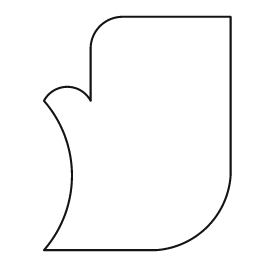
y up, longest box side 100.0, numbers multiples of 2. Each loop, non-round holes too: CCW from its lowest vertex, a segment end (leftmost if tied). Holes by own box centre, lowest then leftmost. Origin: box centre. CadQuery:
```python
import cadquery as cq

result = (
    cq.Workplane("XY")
    .moveTo(-40.0, -50.0)
    .lineTo(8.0, -50.0)
    .threePointArc((30.0, -40.0), (40.0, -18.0))
    .lineTo(40.0, 50.0)
    .lineTo(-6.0, 50.0)
    .threePointArc((-16.0, 46.0), (-20.0, 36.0))
    .lineTo(-20.0, 14.0)
    .threePointArc((-30.0, 20.0), (-40.0, 14.0))
    .threePointArc((-28.0, -18.0), (-40.0, -50.0))
    .close()
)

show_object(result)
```